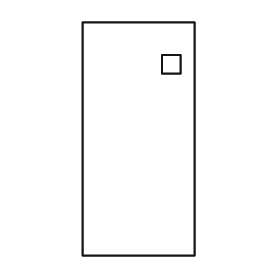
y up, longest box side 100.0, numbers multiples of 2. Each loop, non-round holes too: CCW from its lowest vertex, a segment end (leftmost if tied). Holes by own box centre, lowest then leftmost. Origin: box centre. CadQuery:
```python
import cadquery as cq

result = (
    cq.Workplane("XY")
    .moveTo(-24.0, -50.0)
    .lineTo(24.0, -50.0)
    .lineTo(24.0, 50.0)
    .lineTo(-24.0, 50.0)
    .close()
    .moveTo(10.0, 28.0)
    .lineTo(18.0, 28.0)
    .lineTo(18.0, 36.0)
    .lineTo(10.0, 36.0)
    .close()
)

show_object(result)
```